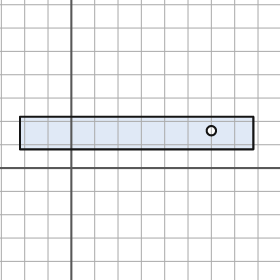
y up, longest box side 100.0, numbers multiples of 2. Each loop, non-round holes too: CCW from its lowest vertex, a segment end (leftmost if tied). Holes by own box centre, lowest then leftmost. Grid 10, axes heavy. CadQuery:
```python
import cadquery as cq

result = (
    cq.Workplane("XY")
    .moveTo(-22.0, 8.0)
    .lineTo(78.0, 8.0)
    .lineTo(78.0, 22.0)
    .lineTo(-22.0, 22.0)
    .close()
    .moveTo(60.0, 16.0)
    .circle(2.0)
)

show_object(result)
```